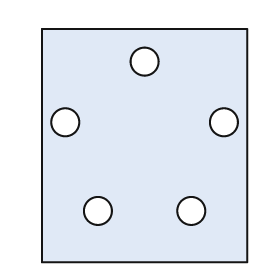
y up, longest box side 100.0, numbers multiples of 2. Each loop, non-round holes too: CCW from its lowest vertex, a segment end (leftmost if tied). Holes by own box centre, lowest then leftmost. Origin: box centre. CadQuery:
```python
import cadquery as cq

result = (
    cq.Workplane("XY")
    .moveTo(-44.0, -50.0)
    .lineTo(44.0, -50.0)
    .lineTo(44.0, 50.0)
    .lineTo(-44.0, 50.0)
    .close()
    .moveTo(-20.0, -28.0)
    .circle(6.0)
    .moveTo(20.0, -28.0)
    .circle(6.0)
    .moveTo(-34.0, 10.0)
    .circle(6.0)
    .moveTo(34.0, 10.0)
    .circle(6.0)
    .moveTo(0.0, 36.0)
    .circle(6.0)
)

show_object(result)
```